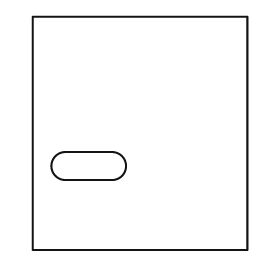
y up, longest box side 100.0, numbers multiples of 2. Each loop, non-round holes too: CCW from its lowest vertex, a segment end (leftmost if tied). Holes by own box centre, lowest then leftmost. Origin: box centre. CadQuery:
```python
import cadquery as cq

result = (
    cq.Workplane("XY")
    .moveTo(-46.0, -50.0)
    .lineTo(46.0, -50.0)
    .lineTo(46.0, 50.0)
    .lineTo(-46.0, 50.0)
    .close()
    .moveTo(-32.0, -20.0)
    .lineTo(-12.0, -20.0)
    .threePointArc((-6.0, -14.0), (-12.0, -8.0))
    .lineTo(-32.0, -8.0)
    .threePointArc((-38.0, -14.0), (-32.0, -20.0))
    .close()
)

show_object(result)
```